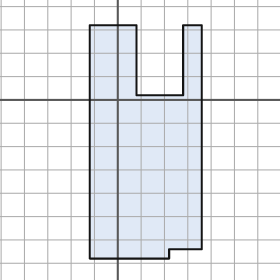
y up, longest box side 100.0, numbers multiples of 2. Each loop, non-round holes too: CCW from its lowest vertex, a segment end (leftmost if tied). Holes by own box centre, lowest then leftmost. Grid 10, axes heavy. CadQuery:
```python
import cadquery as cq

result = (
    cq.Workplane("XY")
    .moveTo(-12.0, -68.0)
    .lineTo(22.0, -68.0)
    .lineTo(22.0, -64.0)
    .lineTo(36.0, -64.0)
    .lineTo(36.0, 32.0)
    .lineTo(28.0, 32.0)
    .lineTo(28.0, 2.0)
    .lineTo(8.0, 2.0)
    .lineTo(8.0, 32.0)
    .lineTo(-12.0, 32.0)
    .close()
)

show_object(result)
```